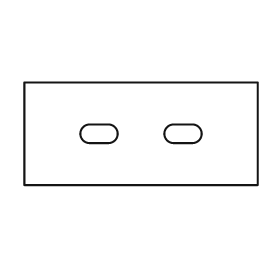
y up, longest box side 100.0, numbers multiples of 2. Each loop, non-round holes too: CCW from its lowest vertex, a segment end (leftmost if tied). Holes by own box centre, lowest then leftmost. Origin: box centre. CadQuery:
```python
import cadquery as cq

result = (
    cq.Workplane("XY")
    .moveTo(-50.0, -22.0)
    .lineTo(50.0, -22.0)
    .lineTo(50.0, 22.0)
    .lineTo(-50.0, 22.0)
    .close()
    .moveTo(-22.0, -4.0)
    .lineTo(-14.0, -4.0)
    .threePointArc((-10.0, 0.0), (-14.0, 4.0))
    .lineTo(-22.0, 4.0)
    .threePointArc((-26.0, 0.0), (-22.0, -4.0))
    .close()
    .moveTo(14.0, -4.0)
    .lineTo(22.0, -4.0)
    .threePointArc((26.0, 0.0), (22.0, 4.0))
    .lineTo(14.0, 4.0)
    .threePointArc((10.0, 0.0), (14.0, -4.0))
    .close()
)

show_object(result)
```